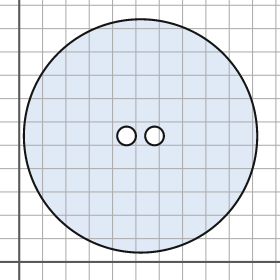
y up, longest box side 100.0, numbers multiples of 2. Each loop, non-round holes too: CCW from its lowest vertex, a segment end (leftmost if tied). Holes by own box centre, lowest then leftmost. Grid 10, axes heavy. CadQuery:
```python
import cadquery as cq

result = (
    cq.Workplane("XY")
    .moveTo(52.0, 54.0)
    .circle(50.0)
    .moveTo(46.0, 54.0)
    .circle(4.0)
    .moveTo(58.0, 54.0)
    .circle(4.0)
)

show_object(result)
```